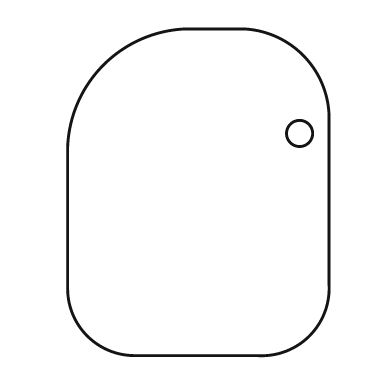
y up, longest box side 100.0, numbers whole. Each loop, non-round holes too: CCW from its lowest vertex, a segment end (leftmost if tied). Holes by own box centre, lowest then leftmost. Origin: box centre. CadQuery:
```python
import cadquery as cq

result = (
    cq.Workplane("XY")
    .moveTo(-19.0, -50.0)
    .lineTo(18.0, -50.0)
    .threePointArc((34.0, -44.0), (40.0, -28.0))
    .lineTo(40.0, 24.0)
    .threePointArc((32.0, 42.0), (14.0, 50.0))
    .lineTo(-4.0, 50.0)
    .threePointArc((-29.0, 39.0), (-40.0, 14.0))
    .lineTo(-40.0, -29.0)
    .threePointArc((-34.0, -44.0), (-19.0, -50.0))
    .close()
    .moveTo(31.0, 18.0)
    .circle(4.0)
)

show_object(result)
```